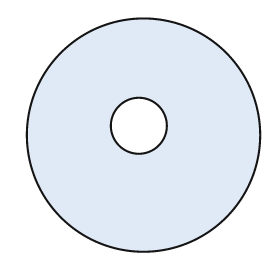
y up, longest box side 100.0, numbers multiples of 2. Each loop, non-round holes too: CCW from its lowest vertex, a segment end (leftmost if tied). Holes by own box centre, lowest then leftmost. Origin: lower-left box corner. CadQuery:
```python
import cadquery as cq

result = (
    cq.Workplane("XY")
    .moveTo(50.0, 50.0)
    .circle(50.0)
    .moveTo(48.0, 54.0)
    .circle(12.0)
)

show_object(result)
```